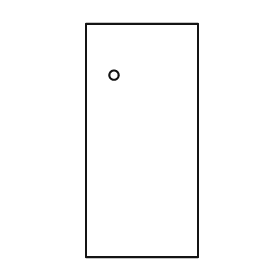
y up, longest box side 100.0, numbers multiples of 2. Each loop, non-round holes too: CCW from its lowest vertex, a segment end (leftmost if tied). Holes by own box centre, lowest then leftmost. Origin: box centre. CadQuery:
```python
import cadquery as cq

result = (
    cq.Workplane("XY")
    .moveTo(-24.0, -50.0)
    .lineTo(24.0, -50.0)
    .lineTo(24.0, 50.0)
    .lineTo(-24.0, 50.0)
    .close()
    .moveTo(-12.0, 28.0)
    .circle(2.0)
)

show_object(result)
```